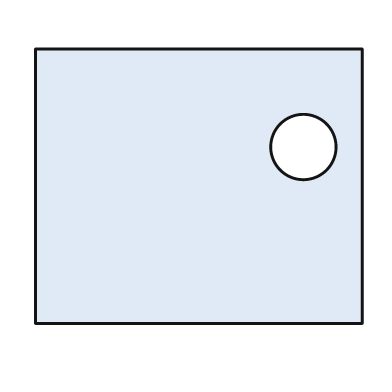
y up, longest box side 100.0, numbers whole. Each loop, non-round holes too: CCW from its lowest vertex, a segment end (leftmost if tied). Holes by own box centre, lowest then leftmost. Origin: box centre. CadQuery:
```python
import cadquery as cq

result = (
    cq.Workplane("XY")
    .moveTo(-50.0, -42.0)
    .lineTo(50.0, -42.0)
    .lineTo(50.0, 42.0)
    .lineTo(-50.0, 42.0)
    .close()
    .moveTo(32.0, 12.0)
    .circle(10.0)
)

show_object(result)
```